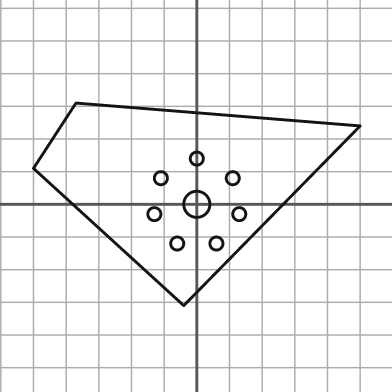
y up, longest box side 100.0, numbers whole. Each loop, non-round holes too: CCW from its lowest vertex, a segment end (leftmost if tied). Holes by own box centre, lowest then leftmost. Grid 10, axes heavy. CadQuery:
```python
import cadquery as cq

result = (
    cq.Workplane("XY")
    .moveTo(-4.0, -31.0)
    .lineTo(50.0, 24.0)
    .lineTo(-37.0, 31.0)
    .lineTo(-50.0, 11.0)
    .close()
    .moveTo(-6.0, -12.0)
    .circle(2.0)
    .moveTo(6.0, -12.0)
    .circle(2.0)
    .moveTo(-13.0, -3.0)
    .circle(2.0)
    .moveTo(13.0, -3.0)
    .circle(2.0)
    .moveTo(0.0, 0.0)
    .circle(4.0)
    .moveTo(-11.0, 8.0)
    .circle(2.0)
    .moveTo(11.0, 8.0)
    .circle(2.0)
    .moveTo(0.0, 14.0)
    .circle(2.0)
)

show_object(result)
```